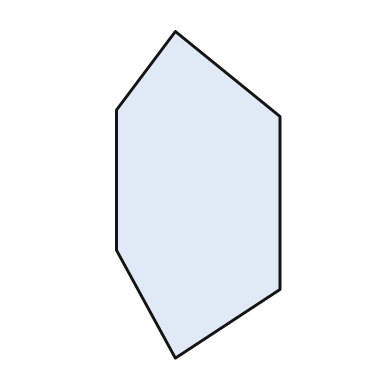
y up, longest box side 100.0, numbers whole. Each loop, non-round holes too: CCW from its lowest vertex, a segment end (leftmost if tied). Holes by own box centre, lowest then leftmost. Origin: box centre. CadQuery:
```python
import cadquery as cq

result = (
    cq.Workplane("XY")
    .moveTo(-7.0, -50.0)
    .lineTo(25.0, -29.0)
    .lineTo(25.0, 24.0)
    .lineTo(-7.0, 50.0)
    .lineTo(-25.0, 26.0)
    .lineTo(-25.0, -17.0)
    .close()
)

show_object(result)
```